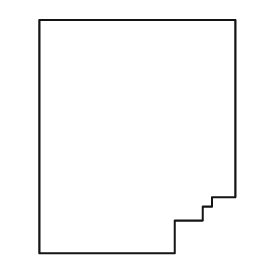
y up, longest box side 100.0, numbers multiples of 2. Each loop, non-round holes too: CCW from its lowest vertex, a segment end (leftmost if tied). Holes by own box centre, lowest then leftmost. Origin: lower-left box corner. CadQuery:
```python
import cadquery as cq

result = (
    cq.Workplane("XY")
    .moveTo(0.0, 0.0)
    .lineTo(58.0, 0.0)
    .lineTo(58.0, 14.0)
    .lineTo(70.0, 14.0)
    .lineTo(70.0, 20.0)
    .lineTo(74.0, 20.0)
    .lineTo(74.0, 24.0)
    .lineTo(84.0, 24.0)
    .lineTo(84.0, 100.0)
    .lineTo(0.0, 100.0)
    .close()
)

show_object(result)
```